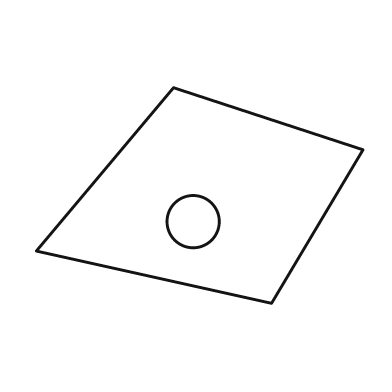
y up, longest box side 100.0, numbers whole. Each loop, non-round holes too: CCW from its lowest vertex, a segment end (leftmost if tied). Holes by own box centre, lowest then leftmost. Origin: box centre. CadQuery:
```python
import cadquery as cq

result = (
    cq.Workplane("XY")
    .moveTo(22.0, -33.0)
    .lineTo(50.0, 14.0)
    .lineTo(-8.0, 33.0)
    .lineTo(-50.0, -17.0)
    .close()
    .moveTo(-2.0, -8.0)
    .circle(8.0)
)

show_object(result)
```